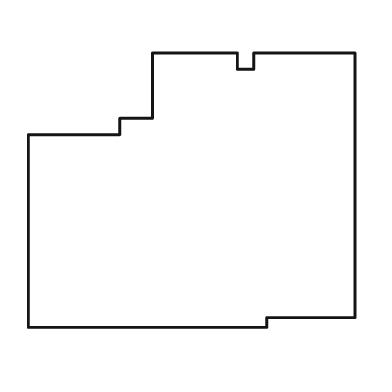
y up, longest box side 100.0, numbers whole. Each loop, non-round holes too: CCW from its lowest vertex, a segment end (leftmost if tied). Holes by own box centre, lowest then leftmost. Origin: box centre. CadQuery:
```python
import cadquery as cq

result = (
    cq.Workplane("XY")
    .moveTo(-50.0, -42.0)
    .lineTo(23.0, -42.0)
    .lineTo(23.0, -39.0)
    .lineTo(50.0, -39.0)
    .lineTo(50.0, 42.0)
    .lineTo(19.0, 42.0)
    .lineTo(19.0, 37.0)
    .lineTo(14.0, 37.0)
    .lineTo(14.0, 42.0)
    .lineTo(-12.0, 42.0)
    .lineTo(-12.0, 22.0)
    .lineTo(-22.0, 22.0)
    .lineTo(-22.0, 17.0)
    .lineTo(-50.0, 17.0)
    .close()
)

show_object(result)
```